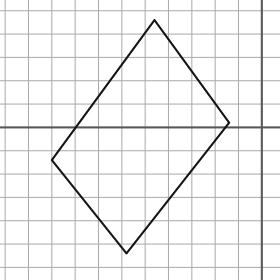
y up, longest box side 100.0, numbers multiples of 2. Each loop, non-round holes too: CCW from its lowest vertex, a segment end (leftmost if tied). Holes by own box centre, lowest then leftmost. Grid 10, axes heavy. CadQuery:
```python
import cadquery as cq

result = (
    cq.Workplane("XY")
    .moveTo(-58.0, -54.0)
    .lineTo(-14.0, 2.0)
    .lineTo(-46.0, 46.0)
    .lineTo(-90.0, -14.0)
    .close()
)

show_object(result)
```